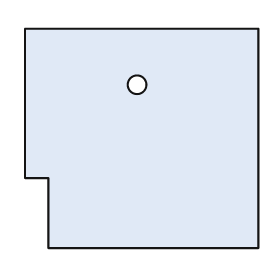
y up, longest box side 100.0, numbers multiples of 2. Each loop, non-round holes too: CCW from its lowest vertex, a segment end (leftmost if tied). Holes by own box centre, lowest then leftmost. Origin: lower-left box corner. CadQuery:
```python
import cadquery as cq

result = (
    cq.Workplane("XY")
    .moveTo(10.0, 0.0)
    .lineTo(100.0, 0.0)
    .lineTo(100.0, 94.0)
    .lineTo(0.0, 94.0)
    .lineTo(0.0, 30.0)
    .lineTo(10.0, 30.0)
    .close()
    .moveTo(48.0, 70.0)
    .circle(4.0)
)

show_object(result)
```